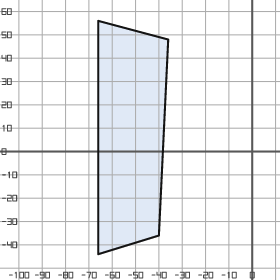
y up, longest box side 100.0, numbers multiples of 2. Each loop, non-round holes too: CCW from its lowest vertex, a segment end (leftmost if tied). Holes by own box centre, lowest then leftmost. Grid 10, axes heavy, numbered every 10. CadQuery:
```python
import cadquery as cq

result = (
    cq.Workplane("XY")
    .moveTo(-66.0, -44.0)
    .lineTo(-40.0, -36.0)
    .lineTo(-36.0, 48.0)
    .lineTo(-66.0, 56.0)
    .close()
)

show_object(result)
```